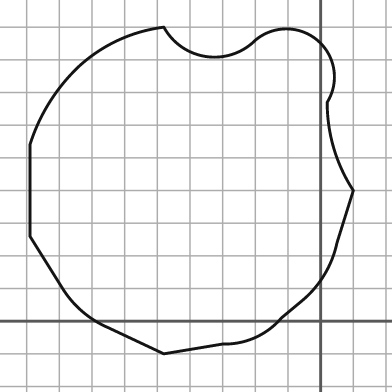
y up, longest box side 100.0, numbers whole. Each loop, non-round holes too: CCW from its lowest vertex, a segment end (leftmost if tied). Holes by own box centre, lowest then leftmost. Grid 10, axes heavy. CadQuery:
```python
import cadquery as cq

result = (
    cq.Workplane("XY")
    .moveTo(-48.0, -10.0)
    .lineTo(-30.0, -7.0)
    .threePointArc((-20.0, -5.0), (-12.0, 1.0))
    .lineTo(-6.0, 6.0)
    .threePointArc((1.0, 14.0), (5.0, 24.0))
    .lineTo(10.0, 40.0)
    .threePointArc((4.0, 53.0), (2.0, 67.0))
    .threePointArc((-1.0, 86.0), (-20.0, 86.0))
    .threePointArc((-35.0, 81.0), (-48.0, 90.0))
    .threePointArc((-62.0, 86.0), (-74.0, 78.0))
    .threePointArc((-83.0, 67.0), (-89.0, 54.0))
    .lineTo(-89.0, 26.0)
    .lineTo(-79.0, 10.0)
    .threePointArc((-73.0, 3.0), (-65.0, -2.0))
    .close()
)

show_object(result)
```